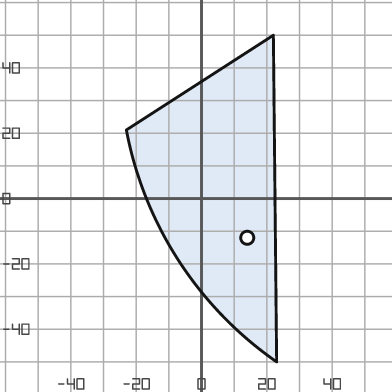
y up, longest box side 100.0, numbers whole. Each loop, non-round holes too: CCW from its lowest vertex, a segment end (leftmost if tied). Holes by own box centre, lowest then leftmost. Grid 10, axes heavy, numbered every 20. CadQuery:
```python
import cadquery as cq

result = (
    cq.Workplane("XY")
    .moveTo(23.0, -50.0)
    .lineTo(22.0, 50.0)
    .lineTo(-23.0, 21.0)
    .threePointArc((-7.0, -19.0), (23.0, -50.0))
    .close()
    .moveTo(14.0, -12.0)
    .circle(2.0)
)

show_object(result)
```